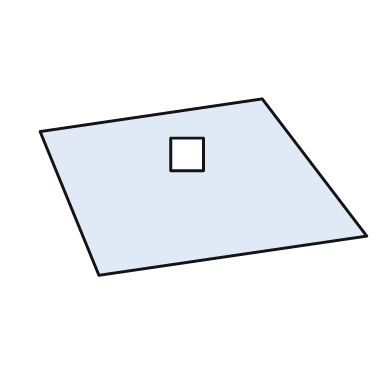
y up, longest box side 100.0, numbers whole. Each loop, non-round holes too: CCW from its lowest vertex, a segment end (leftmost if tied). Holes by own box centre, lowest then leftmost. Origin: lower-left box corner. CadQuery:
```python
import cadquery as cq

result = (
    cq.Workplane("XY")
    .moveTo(18.0, 0.0)
    .lineTo(100.0, 12.0)
    .lineTo(68.0, 54.0)
    .lineTo(0.0, 44.0)
    .close()
    .moveTo(40.0, 32.0)
    .lineTo(50.0, 32.0)
    .lineTo(50.0, 42.0)
    .lineTo(40.0, 42.0)
    .close()
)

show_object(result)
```